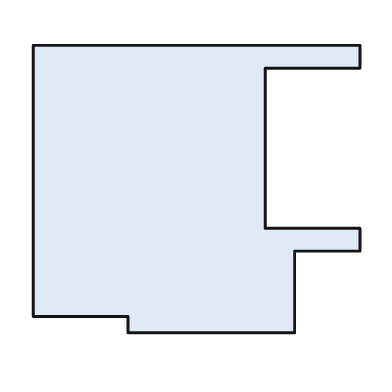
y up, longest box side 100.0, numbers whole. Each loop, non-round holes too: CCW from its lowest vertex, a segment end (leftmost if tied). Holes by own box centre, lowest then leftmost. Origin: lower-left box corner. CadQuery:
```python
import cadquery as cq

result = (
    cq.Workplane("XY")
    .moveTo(29.0, 0.0)
    .lineTo(80.0, 0.0)
    .lineTo(80.0, 25.0)
    .lineTo(100.0, 25.0)
    .lineTo(100.0, 32.0)
    .lineTo(71.0, 32.0)
    .lineTo(71.0, 81.0)
    .lineTo(100.0, 81.0)
    .lineTo(100.0, 88.0)
    .lineTo(0.0, 88.0)
    .lineTo(0.0, 5.0)
    .lineTo(29.0, 5.0)
    .close()
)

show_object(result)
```